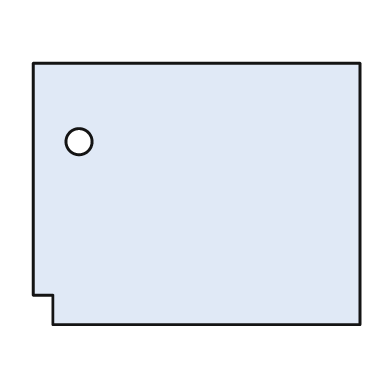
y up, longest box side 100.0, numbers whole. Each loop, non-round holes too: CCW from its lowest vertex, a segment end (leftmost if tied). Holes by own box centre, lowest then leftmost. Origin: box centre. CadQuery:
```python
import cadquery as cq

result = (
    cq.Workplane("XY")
    .moveTo(-44.0, -40.0)
    .lineTo(50.0, -40.0)
    .lineTo(50.0, 40.0)
    .lineTo(-50.0, 40.0)
    .lineTo(-50.0, -31.0)
    .lineTo(-44.0, -31.0)
    .close()
    .moveTo(-36.0, 16.0)
    .circle(4.0)
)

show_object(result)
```